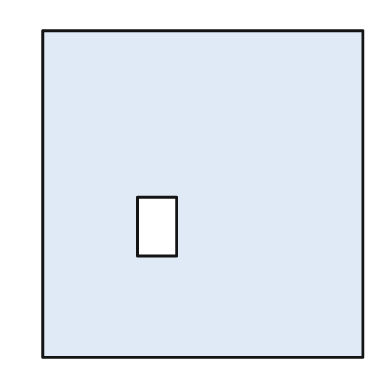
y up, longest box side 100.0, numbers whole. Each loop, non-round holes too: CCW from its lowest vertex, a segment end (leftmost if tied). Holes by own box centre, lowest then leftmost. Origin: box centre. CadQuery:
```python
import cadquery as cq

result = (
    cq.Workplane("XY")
    .moveTo(-49.0, -50.0)
    .lineTo(49.0, -50.0)
    .lineTo(49.0, 50.0)
    .lineTo(-49.0, 50.0)
    .close()
    .moveTo(-20.0, -19.0)
    .lineTo(-8.0, -19.0)
    .lineTo(-8.0, -1.0)
    .lineTo(-20.0, -1.0)
    .close()
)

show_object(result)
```